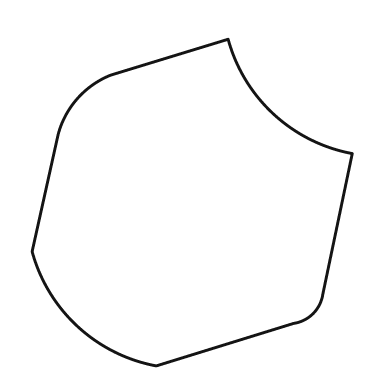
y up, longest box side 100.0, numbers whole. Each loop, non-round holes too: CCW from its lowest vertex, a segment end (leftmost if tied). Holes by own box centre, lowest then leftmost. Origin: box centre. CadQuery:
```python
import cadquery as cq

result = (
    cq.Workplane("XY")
    .moveTo(-11.0, -50.0)
    .lineTo(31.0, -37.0)
    .threePointArc((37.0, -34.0), (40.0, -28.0))
    .lineTo(49.0, 15.0)
    .threePointArc((25.0, 27.0), (11.0, 50.0))
    .lineTo(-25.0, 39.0)
    .threePointArc((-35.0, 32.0), (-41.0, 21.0))
    .lineTo(-49.0, -15.0)
    .threePointArc((-35.0, -38.0), (-11.0, -50.0))
    .close()
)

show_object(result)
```